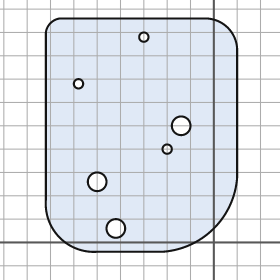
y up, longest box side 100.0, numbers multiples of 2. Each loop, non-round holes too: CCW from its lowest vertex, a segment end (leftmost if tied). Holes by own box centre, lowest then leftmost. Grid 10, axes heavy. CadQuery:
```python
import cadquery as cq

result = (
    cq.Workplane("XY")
    .moveTo(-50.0, -4.0)
    .lineTo(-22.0, -4.0)
    .threePointArc((0.0, 6.0), (10.0, 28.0))
    .lineTo(10.0, 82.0)
    .threePointArc((6.0, 92.0), (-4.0, 96.0))
    .lineTo(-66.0, 96.0)
    .threePointArc((-70.0, 94.0), (-72.0, 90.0))
    .lineTo(-72.0, 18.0)
    .threePointArc((-66.0, 2.0), (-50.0, -4.0))
    .close()
    .moveTo(-42.0, 6.0)
    .circle(4.0)
    .moveTo(-50.0, 26.0)
    .circle(4.0)
    .moveTo(-20.0, 40.0)
    .circle(2.0)
    .moveTo(-14.0, 50.0)
    .circle(4.0)
    .moveTo(-58.0, 68.0)
    .circle(2.0)
    .moveTo(-30.0, 88.0)
    .circle(2.0)
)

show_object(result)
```